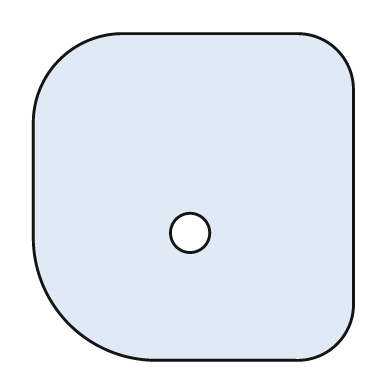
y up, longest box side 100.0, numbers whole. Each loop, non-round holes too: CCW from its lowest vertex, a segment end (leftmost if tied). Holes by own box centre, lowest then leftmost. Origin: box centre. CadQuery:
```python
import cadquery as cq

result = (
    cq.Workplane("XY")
    .moveTo(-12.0, -50.0)
    .lineTo(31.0, -50.0)
    .threePointArc((44.0, -45.0), (49.0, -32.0))
    .lineTo(49.0, 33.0)
    .threePointArc((44.0, 45.0), (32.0, 50.0))
    .lineTo(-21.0, 50.0)
    .threePointArc((-41.0, 42.0), (-49.0, 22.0))
    .lineTo(-49.0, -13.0)
    .threePointArc((-38.0, -39.0), (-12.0, -50.0))
    .close()
    .moveTo(-1.0, -11.0)
    .circle(6.0)
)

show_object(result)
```